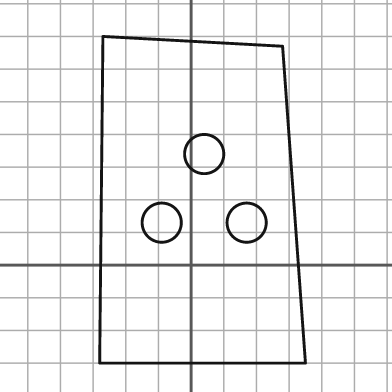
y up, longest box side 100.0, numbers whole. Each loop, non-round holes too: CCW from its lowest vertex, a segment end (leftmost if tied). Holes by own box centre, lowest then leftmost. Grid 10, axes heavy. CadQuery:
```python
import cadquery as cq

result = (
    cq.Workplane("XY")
    .moveTo(-28.0, -30.0)
    .lineTo(35.0, -30.0)
    .lineTo(28.0, 67.0)
    .lineTo(-27.0, 70.0)
    .close()
    .moveTo(-9.0, 13.0)
    .circle(6.0)
    .moveTo(17.0, 13.0)
    .circle(6.0)
    .moveTo(4.0, 34.0)
    .circle(6.0)
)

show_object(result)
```